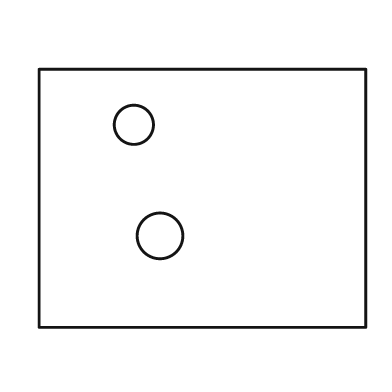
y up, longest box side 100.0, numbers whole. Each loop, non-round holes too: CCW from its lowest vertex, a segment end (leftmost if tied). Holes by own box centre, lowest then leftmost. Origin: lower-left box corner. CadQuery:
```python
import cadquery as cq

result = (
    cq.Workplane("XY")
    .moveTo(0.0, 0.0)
    .lineTo(100.0, 0.0)
    .lineTo(100.0, 79.0)
    .lineTo(0.0, 79.0)
    .close()
    .moveTo(37.0, 28.0)
    .circle(7.0)
    .moveTo(29.0, 62.0)
    .circle(6.0)
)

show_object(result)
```